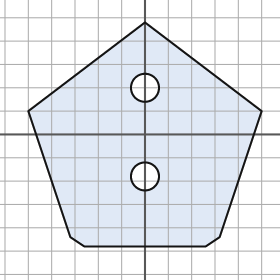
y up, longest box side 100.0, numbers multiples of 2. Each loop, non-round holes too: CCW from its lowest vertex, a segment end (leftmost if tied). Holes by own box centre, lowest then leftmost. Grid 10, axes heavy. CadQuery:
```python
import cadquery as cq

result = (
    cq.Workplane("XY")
    .moveTo(-26.0, -48.0)
    .lineTo(26.0, -48.0)
    .lineTo(32.0, -44.0)
    .lineTo(50.0, 10.0)
    .lineTo(0.0, 48.0)
    .lineTo(-50.0, 10.0)
    .lineTo(-32.0, -44.0)
    .close()
    .moveTo(0.0, -18.0)
    .circle(6.0)
    .moveTo(0.0, 20.0)
    .circle(6.0)
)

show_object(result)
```